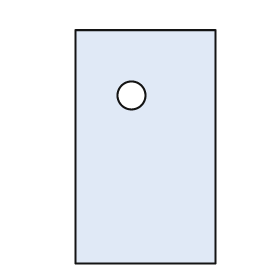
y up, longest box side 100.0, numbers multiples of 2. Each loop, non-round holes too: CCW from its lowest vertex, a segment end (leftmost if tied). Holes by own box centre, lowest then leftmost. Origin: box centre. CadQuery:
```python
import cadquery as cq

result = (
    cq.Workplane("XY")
    .moveTo(-30.0, -50.0)
    .lineTo(30.0, -50.0)
    .lineTo(30.0, 50.0)
    .lineTo(-30.0, 50.0)
    .close()
    .moveTo(-6.0, 22.0)
    .circle(6.0)
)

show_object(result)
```